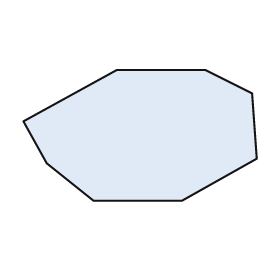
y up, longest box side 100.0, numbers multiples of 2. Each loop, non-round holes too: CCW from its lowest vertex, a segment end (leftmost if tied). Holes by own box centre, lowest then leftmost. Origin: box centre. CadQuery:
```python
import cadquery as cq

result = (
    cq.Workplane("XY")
    .moveTo(-20.0, -28.0)
    .lineTo(18.0, -28.0)
    .lineTo(50.0, -10.0)
    .lineTo(48.0, 18.0)
    .lineTo(28.0, 28.0)
    .lineTo(-10.0, 28.0)
    .lineTo(-50.0, 6.0)
    .lineTo(-40.0, -12.0)
    .close()
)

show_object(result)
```